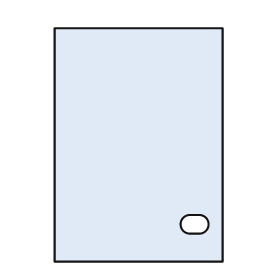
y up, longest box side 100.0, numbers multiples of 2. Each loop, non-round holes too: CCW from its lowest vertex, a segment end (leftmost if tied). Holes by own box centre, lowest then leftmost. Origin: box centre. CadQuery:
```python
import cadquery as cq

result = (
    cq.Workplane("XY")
    .moveTo(-36.0, -50.0)
    .lineTo(36.0, -50.0)
    .lineTo(36.0, 50.0)
    .lineTo(-36.0, 50.0)
    .close()
    .moveTo(22.0, -38.0)
    .lineTo(26.0, -38.0)
    .threePointArc((30.0, -34.0), (26.0, -30.0))
    .lineTo(22.0, -30.0)
    .threePointArc((18.0, -34.0), (22.0, -38.0))
    .close()
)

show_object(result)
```